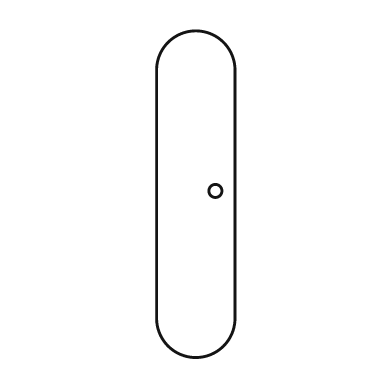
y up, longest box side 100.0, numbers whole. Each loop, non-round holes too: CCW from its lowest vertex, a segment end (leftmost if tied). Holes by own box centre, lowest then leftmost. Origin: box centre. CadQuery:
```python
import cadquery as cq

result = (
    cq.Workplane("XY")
    .moveTo(-12.0, -38.0)
    .threePointArc((0.0, -50.0), (12.0, -38.0))
    .lineTo(12.0, 38.0)
    .threePointArc((0.0, 50.0), (-12.0, 38.0))
    .close()
    .moveTo(6.0, 1.0)
    .circle(2.0)
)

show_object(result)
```